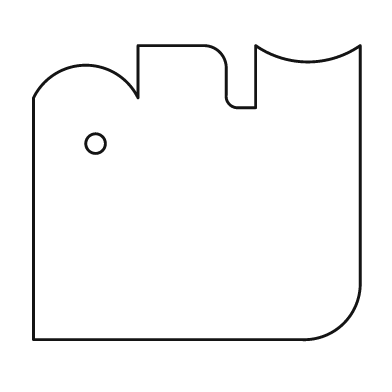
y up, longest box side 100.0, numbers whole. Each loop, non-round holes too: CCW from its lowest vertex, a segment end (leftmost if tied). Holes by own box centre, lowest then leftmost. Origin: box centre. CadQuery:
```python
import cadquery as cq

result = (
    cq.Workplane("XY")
    .moveTo(-50.0, -45.0)
    .lineTo(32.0, -45.0)
    .threePointArc((45.0, -40.0), (50.0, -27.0))
    .lineTo(50.0, 45.0)
    .threePointArc((34.0, 40.0), (18.0, 45.0))
    .lineTo(18.0, 26.0)
    .lineTo(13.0, 26.0)
    .threePointArc((10.0, 27.0), (9.0, 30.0))
    .lineTo(9.0, 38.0)
    .threePointArc((7.0, 43.0), (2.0, 45.0))
    .lineTo(-18.0, 45.0)
    .lineTo(-18.0, 29.0)
    .threePointArc((-34.0, 39.0), (-50.0, 29.0))
    .close()
    .moveTo(-31.0, 15.0)
    .circle(3.0)
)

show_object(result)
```